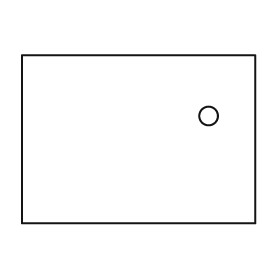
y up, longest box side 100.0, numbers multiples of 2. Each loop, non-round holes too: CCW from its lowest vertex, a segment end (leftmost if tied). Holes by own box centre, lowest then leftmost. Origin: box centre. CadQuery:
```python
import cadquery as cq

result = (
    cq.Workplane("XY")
    .moveTo(-50.0, -36.0)
    .lineTo(50.0, -36.0)
    .lineTo(50.0, 36.0)
    .lineTo(-50.0, 36.0)
    .close()
    .moveTo(30.0, 10.0)
    .circle(4.0)
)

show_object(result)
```